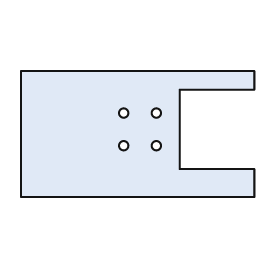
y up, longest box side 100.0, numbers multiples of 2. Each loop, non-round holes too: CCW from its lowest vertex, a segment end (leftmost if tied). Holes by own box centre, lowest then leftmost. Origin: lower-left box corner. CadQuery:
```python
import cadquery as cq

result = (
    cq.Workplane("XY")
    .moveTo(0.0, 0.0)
    .lineTo(100.0, 0.0)
    .lineTo(100.0, 12.0)
    .lineTo(68.0, 12.0)
    .lineTo(68.0, 46.0)
    .lineTo(100.0, 46.0)
    .lineTo(100.0, 54.0)
    .lineTo(0.0, 54.0)
    .close()
    .moveTo(44.0, 22.0)
    .circle(2.0)
    .moveTo(58.0, 22.0)
    .circle(2.0)
    .moveTo(44.0, 36.0)
    .circle(2.0)
    .moveTo(58.0, 36.0)
    .circle(2.0)
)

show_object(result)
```